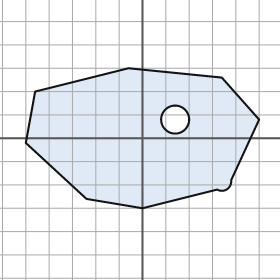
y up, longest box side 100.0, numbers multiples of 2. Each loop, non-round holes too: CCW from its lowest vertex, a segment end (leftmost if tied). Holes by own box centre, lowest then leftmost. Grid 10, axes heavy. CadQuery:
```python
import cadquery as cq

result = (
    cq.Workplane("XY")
    .moveTo(0.0, -30.0)
    .lineTo(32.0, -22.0)
    .threePointArc((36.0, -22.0), (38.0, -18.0))
    .lineTo(50.0, 8.0)
    .lineTo(34.0, 26.0)
    .lineTo(-6.0, 30.0)
    .lineTo(-46.0, 20.0)
    .lineTo(-50.0, -2.0)
    .lineTo(-24.0, -26.0)
    .close()
    .moveTo(14.0, 8.0)
    .circle(6.0)
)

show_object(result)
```